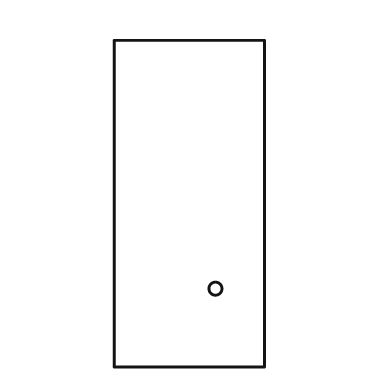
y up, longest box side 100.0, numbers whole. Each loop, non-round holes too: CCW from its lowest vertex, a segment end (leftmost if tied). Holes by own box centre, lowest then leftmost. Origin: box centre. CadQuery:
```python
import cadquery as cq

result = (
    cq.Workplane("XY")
    .moveTo(-23.0, -50.0)
    .lineTo(23.0, -50.0)
    .lineTo(23.0, 50.0)
    .lineTo(-23.0, 50.0)
    .close()
    .moveTo(8.0, -26.0)
    .circle(2.0)
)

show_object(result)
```